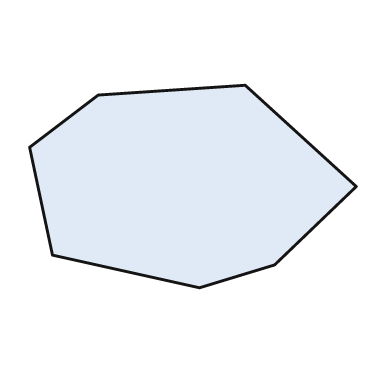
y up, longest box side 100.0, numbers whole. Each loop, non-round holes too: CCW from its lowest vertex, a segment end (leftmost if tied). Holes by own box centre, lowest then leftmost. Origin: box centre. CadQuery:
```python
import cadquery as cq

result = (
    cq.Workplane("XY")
    .moveTo(2.0, -31.0)
    .lineTo(25.0, -24.0)
    .lineTo(50.0, 0.0)
    .lineTo(16.0, 31.0)
    .lineTo(-29.0, 28.0)
    .lineTo(-50.0, 12.0)
    .lineTo(-43.0, -21.0)
    .close()
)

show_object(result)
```